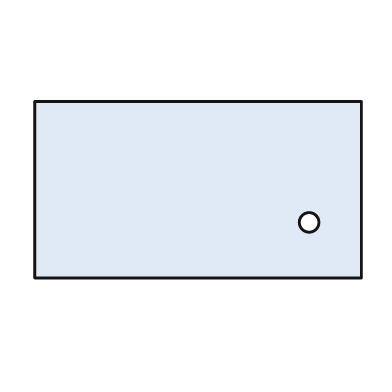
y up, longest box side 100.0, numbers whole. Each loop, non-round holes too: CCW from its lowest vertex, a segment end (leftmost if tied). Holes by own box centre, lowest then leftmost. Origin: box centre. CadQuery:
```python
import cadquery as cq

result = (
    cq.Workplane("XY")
    .moveTo(-50.0, -27.0)
    .lineTo(50.0, -27.0)
    .lineTo(50.0, 27.0)
    .lineTo(-50.0, 27.0)
    .close()
    .moveTo(34.0, -10.0)
    .circle(3.0)
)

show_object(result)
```